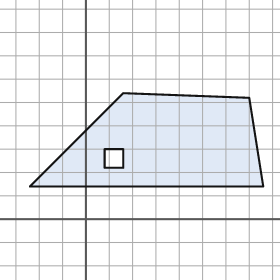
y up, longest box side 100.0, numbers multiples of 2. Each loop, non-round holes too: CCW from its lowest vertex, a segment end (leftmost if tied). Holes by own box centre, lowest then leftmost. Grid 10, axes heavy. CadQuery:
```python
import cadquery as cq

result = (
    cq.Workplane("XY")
    .moveTo(-24.0, 14.0)
    .lineTo(76.0, 14.0)
    .lineTo(70.0, 52.0)
    .lineTo(16.0, 54.0)
    .close()
    .moveTo(8.0, 22.0)
    .lineTo(16.0, 22.0)
    .lineTo(16.0, 30.0)
    .lineTo(8.0, 30.0)
    .close()
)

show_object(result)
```